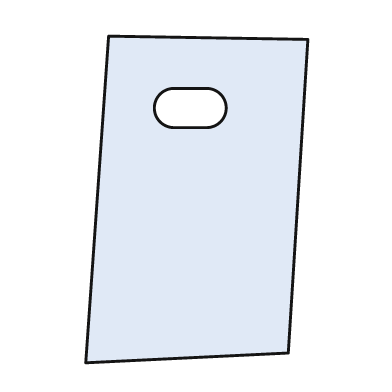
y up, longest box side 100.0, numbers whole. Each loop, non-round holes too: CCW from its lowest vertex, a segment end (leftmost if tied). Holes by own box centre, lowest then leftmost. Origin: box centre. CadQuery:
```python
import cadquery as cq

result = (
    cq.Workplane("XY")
    .moveTo(-34.0, -50.0)
    .lineTo(28.0, -47.0)
    .lineTo(34.0, 49.0)
    .lineTo(-27.0, 50.0)
    .close()
    .moveTo(-7.0, 22.0)
    .lineTo(3.0, 22.0)
    .threePointArc((9.0, 28.0), (3.0, 34.0))
    .lineTo(-7.0, 34.0)
    .threePointArc((-13.0, 28.0), (-7.0, 22.0))
    .close()
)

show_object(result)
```